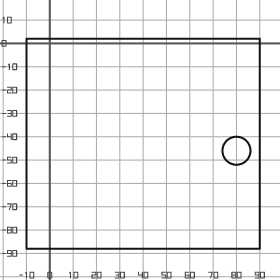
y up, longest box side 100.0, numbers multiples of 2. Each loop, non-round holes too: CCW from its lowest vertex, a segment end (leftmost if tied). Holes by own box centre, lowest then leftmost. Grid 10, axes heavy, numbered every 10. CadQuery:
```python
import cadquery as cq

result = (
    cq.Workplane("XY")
    .moveTo(-10.0, -88.0)
    .lineTo(90.0, -88.0)
    .lineTo(90.0, 2.0)
    .lineTo(-10.0, 2.0)
    .close()
    .moveTo(80.0, -46.0)
    .circle(6.0)
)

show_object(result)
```